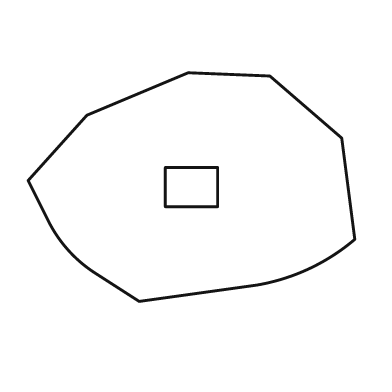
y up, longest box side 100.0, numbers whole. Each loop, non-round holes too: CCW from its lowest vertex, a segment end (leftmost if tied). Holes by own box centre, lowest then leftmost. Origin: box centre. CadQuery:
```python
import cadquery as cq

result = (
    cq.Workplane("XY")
    .moveTo(-16.0, -35.0)
    .lineTo(20.0, -30.0)
    .threePointArc((36.0, -25.0), (50.0, -16.0))
    .lineTo(46.0, 15.0)
    .lineTo(24.0, 34.0)
    .lineTo(-1.0, 35.0)
    .lineTo(-32.0, 22.0)
    .lineTo(-50.0, 2.0)
    .lineTo(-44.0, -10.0)
    .threePointArc((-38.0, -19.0), (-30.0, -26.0))
    .close()
    .moveTo(-8.0, -6.0)
    .lineTo(8.0, -6.0)
    .lineTo(8.0, 6.0)
    .lineTo(-8.0, 6.0)
    .close()
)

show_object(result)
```